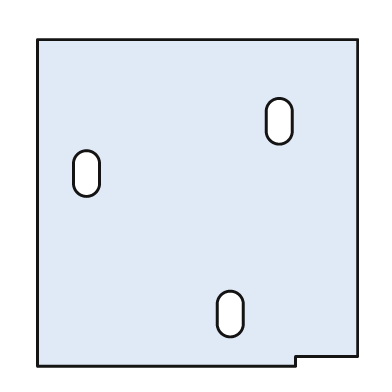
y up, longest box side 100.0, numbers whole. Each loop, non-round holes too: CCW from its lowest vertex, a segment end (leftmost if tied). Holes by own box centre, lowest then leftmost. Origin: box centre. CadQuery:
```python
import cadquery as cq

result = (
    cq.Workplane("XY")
    .moveTo(-49.0, -50.0)
    .lineTo(30.0, -50.0)
    .lineTo(30.0, -47.0)
    .lineTo(49.0, -47.0)
    .lineTo(49.0, 50.0)
    .lineTo(-49.0, 50.0)
    .close()
    .moveTo(6.0, -37.0)
    .threePointArc((10.0, -41.0), (14.0, -37.0))
    .lineTo(14.0, -31.0)
    .threePointArc((10.0, -27.0), (6.0, -31.0))
    .close()
    .moveTo(-38.0, 6.0)
    .threePointArc((-34.0, 2.0), (-30.0, 6.0))
    .lineTo(-30.0, 12.0)
    .threePointArc((-34.0, 16.0), (-38.0, 12.0))
    .close()
    .moveTo(21.0, 22.0)
    .threePointArc((25.0, 18.0), (29.0, 22.0))
    .lineTo(29.0, 28.0)
    .threePointArc((25.0, 32.0), (21.0, 28.0))
    .close()
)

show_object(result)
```